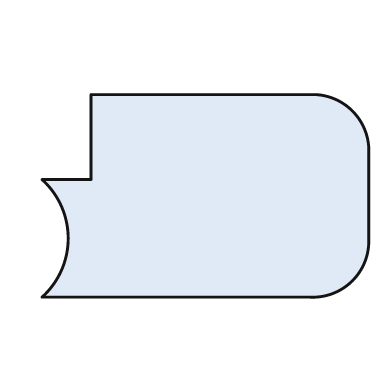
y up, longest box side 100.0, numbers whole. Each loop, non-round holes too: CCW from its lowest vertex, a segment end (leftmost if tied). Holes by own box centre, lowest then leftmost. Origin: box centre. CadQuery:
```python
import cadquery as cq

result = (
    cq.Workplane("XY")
    .moveTo(-50.0, -31.0)
    .lineTo(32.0, -31.0)
    .threePointArc((45.0, -26.0), (50.0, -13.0))
    .lineTo(50.0, 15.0)
    .threePointArc((45.0, 26.0), (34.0, 31.0))
    .lineTo(-35.0, 31.0)
    .lineTo(-35.0, 5.0)
    .lineTo(-50.0, 5.0)
    .threePointArc((-42.0, -13.0), (-50.0, -31.0))
    .close()
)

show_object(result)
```